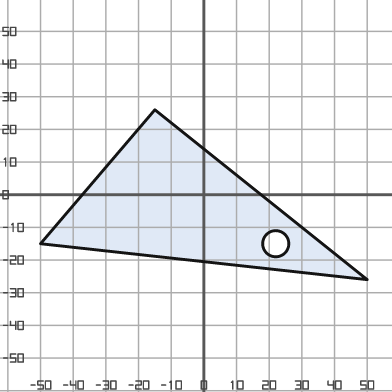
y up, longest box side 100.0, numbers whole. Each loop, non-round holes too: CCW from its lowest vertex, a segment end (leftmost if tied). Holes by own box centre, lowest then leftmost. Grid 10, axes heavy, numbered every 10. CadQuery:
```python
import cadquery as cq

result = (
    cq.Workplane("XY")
    .moveTo(50.0, -26.0)
    .lineTo(-15.0, 26.0)
    .lineTo(-50.0, -15.0)
    .close()
    .moveTo(22.0, -15.0)
    .circle(4.0)
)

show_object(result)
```